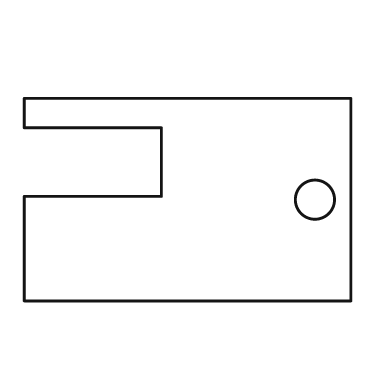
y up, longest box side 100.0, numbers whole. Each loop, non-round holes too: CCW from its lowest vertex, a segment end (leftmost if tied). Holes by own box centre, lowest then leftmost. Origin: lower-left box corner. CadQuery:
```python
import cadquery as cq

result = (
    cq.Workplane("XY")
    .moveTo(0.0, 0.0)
    .lineTo(100.0, 0.0)
    .lineTo(100.0, 62.0)
    .lineTo(0.0, 62.0)
    .lineTo(0.0, 53.0)
    .lineTo(42.0, 53.0)
    .lineTo(42.0, 32.0)
    .lineTo(0.0, 32.0)
    .close()
    .moveTo(89.0, 31.0)
    .circle(6.0)
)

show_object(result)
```